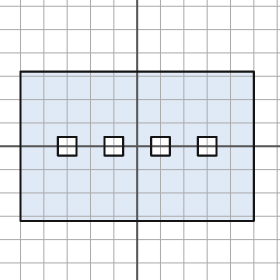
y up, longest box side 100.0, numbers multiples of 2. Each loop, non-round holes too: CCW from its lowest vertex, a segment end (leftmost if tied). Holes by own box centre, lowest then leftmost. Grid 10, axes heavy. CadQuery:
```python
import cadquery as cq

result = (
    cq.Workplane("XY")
    .moveTo(-50.0, -32.0)
    .lineTo(50.0, -32.0)
    .lineTo(50.0, 32.0)
    .lineTo(-50.0, 32.0)
    .close()
    .moveTo(-34.0, -4.0)
    .lineTo(-26.0, -4.0)
    .lineTo(-26.0, 4.0)
    .lineTo(-34.0, 4.0)
    .close()
    .moveTo(-14.0, -4.0)
    .lineTo(-6.0, -4.0)
    .lineTo(-6.0, 4.0)
    .lineTo(-14.0, 4.0)
    .close()
    .moveTo(6.0, -4.0)
    .lineTo(14.0, -4.0)
    .lineTo(14.0, 4.0)
    .lineTo(6.0, 4.0)
    .close()
    .moveTo(26.0, -4.0)
    .lineTo(34.0, -4.0)
    .lineTo(34.0, 4.0)
    .lineTo(26.0, 4.0)
    .close()
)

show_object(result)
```